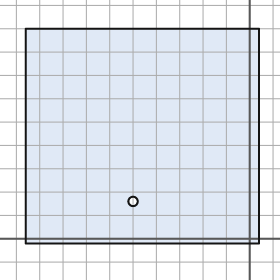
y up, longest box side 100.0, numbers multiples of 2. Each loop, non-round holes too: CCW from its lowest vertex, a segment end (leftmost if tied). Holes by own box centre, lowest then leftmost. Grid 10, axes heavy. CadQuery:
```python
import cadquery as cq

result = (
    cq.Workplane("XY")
    .moveTo(-96.0, -2.0)
    .lineTo(4.0, -2.0)
    .lineTo(4.0, 90.0)
    .lineTo(-96.0, 90.0)
    .close()
    .moveTo(-50.0, 16.0)
    .circle(2.0)
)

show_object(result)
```